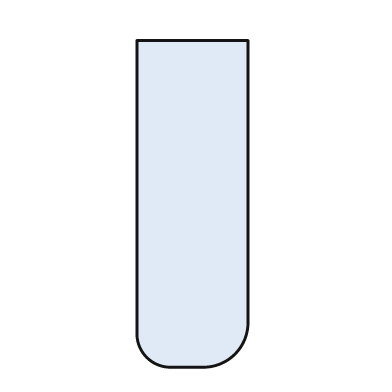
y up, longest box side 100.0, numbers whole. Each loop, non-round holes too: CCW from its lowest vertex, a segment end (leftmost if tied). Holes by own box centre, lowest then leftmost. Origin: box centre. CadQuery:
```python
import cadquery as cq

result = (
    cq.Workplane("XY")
    .moveTo(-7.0, -50.0)
    .lineTo(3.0, -50.0)
    .threePointArc((13.0, -46.0), (17.0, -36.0))
    .lineTo(17.0, 50.0)
    .lineTo(-17.0, 50.0)
    .lineTo(-17.0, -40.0)
    .threePointArc((-14.0, -47.0), (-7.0, -50.0))
    .close()
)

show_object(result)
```